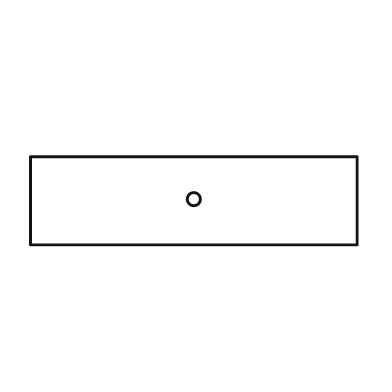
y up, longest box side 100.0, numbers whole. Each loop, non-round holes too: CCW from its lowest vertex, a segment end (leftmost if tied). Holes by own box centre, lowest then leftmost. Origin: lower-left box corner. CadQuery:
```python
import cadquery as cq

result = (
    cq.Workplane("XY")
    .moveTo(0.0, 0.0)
    .lineTo(100.0, 0.0)
    .lineTo(100.0, 27.0)
    .lineTo(0.0, 27.0)
    .close()
    .moveTo(50.0, 14.0)
    .circle(2.0)
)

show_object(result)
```